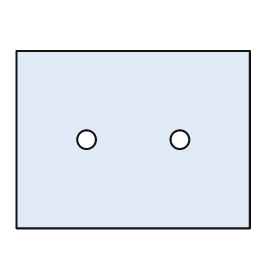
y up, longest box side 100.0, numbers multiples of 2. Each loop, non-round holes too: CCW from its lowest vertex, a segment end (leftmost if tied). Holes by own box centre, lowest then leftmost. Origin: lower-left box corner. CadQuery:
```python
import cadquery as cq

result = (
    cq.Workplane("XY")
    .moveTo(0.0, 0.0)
    .lineTo(100.0, 0.0)
    .lineTo(100.0, 76.0)
    .lineTo(0.0, 76.0)
    .close()
    .moveTo(30.0, 38.0)
    .circle(4.0)
    .moveTo(70.0, 38.0)
    .circle(4.0)
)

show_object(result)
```